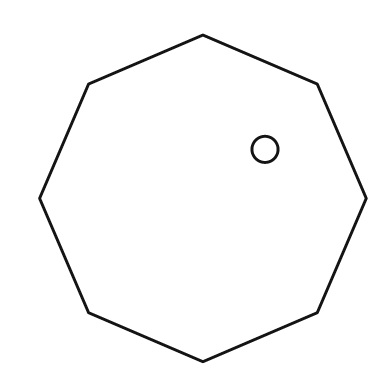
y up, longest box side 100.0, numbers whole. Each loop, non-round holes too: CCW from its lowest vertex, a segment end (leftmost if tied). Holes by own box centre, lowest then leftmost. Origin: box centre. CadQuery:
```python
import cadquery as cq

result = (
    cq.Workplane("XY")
    .moveTo(0.0, -50.0)
    .lineTo(35.0, -35.0)
    .lineTo(50.0, 0.0)
    .lineTo(35.0, 35.0)
    .lineTo(0.0, 50.0)
    .lineTo(-35.0, 35.0)
    .lineTo(-50.0, 0.0)
    .lineTo(-35.0, -35.0)
    .close()
    .moveTo(19.0, 15.0)
    .circle(4.0)
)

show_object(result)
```